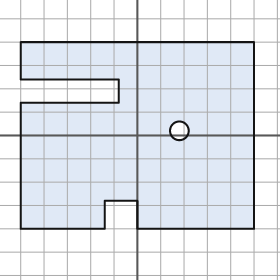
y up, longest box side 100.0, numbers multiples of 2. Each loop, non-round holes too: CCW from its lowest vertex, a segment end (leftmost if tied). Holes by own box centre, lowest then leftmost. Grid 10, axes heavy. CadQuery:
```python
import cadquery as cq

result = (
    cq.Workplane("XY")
    .moveTo(-50.0, -40.0)
    .lineTo(-14.0, -40.0)
    .lineTo(-14.0, -28.0)
    .lineTo(0.0, -28.0)
    .lineTo(0.0, -40.0)
    .lineTo(50.0, -40.0)
    .lineTo(50.0, 40.0)
    .lineTo(-50.0, 40.0)
    .lineTo(-50.0, 24.0)
    .lineTo(-8.0, 24.0)
    .lineTo(-8.0, 14.0)
    .lineTo(-50.0, 14.0)
    .close()
    .moveTo(18.0, 2.0)
    .circle(4.0)
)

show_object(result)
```